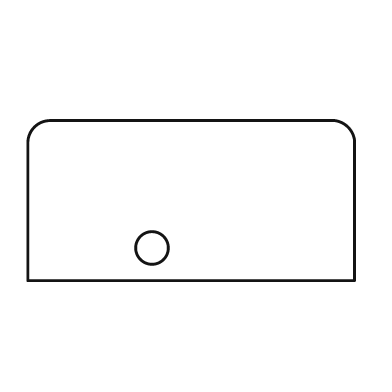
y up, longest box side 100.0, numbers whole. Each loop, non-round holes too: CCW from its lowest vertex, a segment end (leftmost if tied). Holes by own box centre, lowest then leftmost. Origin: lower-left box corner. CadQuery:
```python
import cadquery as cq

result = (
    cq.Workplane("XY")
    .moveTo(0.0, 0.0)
    .lineTo(100.0, 0.0)
    .lineTo(100.0, 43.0)
    .threePointArc((98.0, 47.0), (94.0, 49.0))
    .lineTo(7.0, 49.0)
    .threePointArc((2.0, 47.0), (0.0, 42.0))
    .close()
    .moveTo(38.0, 10.0)
    .circle(5.0)
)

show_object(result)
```